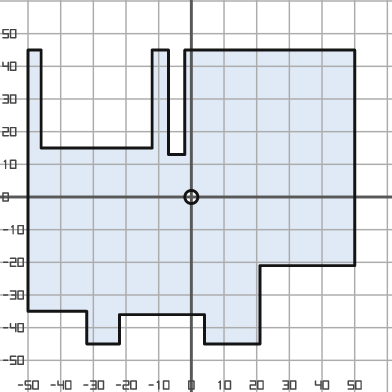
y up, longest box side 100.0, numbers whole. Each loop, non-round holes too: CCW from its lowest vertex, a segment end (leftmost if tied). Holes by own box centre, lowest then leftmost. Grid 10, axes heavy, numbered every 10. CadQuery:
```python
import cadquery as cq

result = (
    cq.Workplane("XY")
    .moveTo(-32.0, -45.0)
    .lineTo(-22.0, -45.0)
    .lineTo(-22.0, -36.0)
    .lineTo(4.0, -36.0)
    .lineTo(4.0, -45.0)
    .lineTo(21.0, -45.0)
    .lineTo(21.0, -21.0)
    .lineTo(50.0, -21.0)
    .lineTo(50.0, 45.0)
    .lineTo(-2.0, 45.0)
    .lineTo(-2.0, 13.0)
    .lineTo(-7.0, 13.0)
    .lineTo(-7.0, 45.0)
    .lineTo(-12.0, 45.0)
    .lineTo(-12.0, 15.0)
    .lineTo(-46.0, 15.0)
    .lineTo(-46.0, 45.0)
    .lineTo(-50.0, 45.0)
    .lineTo(-50.0, -35.0)
    .lineTo(-32.0, -35.0)
    .close()
    .moveTo(0.0, 0.0)
    .circle(2.0)
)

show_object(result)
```